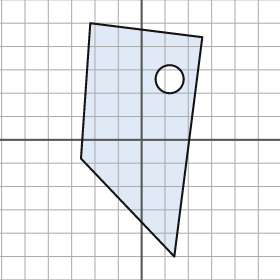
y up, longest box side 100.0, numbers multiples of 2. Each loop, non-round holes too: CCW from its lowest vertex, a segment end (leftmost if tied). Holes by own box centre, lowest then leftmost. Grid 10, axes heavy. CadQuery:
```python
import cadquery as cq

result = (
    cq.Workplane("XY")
    .moveTo(14.0, -50.0)
    .lineTo(26.0, 44.0)
    .lineTo(-22.0, 50.0)
    .lineTo(-26.0, -8.0)
    .close()
    .moveTo(12.0, 26.0)
    .circle(6.0)
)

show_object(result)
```